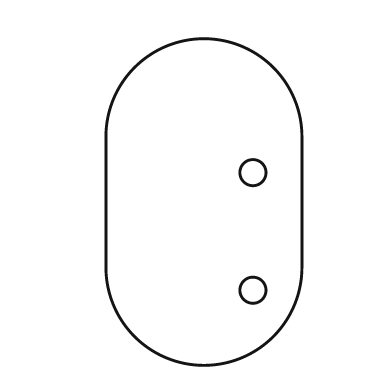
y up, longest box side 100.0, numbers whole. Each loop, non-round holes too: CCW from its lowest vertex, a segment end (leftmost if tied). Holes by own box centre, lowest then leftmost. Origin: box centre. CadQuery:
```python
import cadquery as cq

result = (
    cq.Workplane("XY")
    .moveTo(-30.0, -20.0)
    .threePointArc((0.0, -50.0), (30.0, -20.0))
    .lineTo(30.0, 20.0)
    .threePointArc((0.0, 50.0), (-30.0, 20.0))
    .close()
    .moveTo(15.0, -27.0)
    .circle(4.0)
    .moveTo(15.0, 9.0)
    .circle(4.0)
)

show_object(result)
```